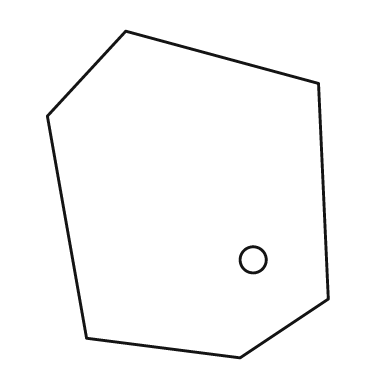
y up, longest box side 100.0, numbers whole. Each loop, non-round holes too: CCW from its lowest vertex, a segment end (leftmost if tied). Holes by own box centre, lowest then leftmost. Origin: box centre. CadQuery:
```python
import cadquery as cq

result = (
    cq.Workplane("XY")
    .moveTo(16.0, -50.0)
    .lineTo(43.0, -32.0)
    .lineTo(40.0, 34.0)
    .lineTo(-19.0, 50.0)
    .lineTo(-43.0, 24.0)
    .lineTo(-31.0, -44.0)
    .close()
    .moveTo(20.0, -20.0)
    .circle(4.0)
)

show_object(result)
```